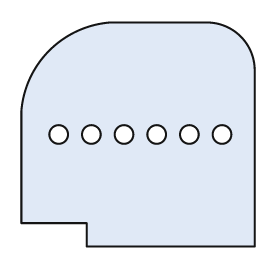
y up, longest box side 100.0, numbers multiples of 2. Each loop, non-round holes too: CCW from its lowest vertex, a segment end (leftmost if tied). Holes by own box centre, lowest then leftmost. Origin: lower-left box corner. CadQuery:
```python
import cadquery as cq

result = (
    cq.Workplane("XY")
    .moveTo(28.0, 0.0)
    .lineTo(100.0, 0.0)
    .lineTo(100.0, 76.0)
    .threePointArc((94.0, 90.0), (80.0, 96.0))
    .lineTo(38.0, 96.0)
    .threePointArc((12.0, 84.0), (0.0, 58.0))
    .lineTo(0.0, 10.0)
    .lineTo(28.0, 10.0)
    .close()
    .moveTo(16.0, 48.0)
    .circle(4.0)
    .moveTo(30.0, 48.0)
    .circle(4.0)
    .moveTo(44.0, 48.0)
    .circle(4.0)
    .moveTo(58.0, 48.0)
    .circle(4.0)
    .moveTo(72.0, 48.0)
    .circle(4.0)
    .moveTo(86.0, 48.0)
    .circle(4.0)
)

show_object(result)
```